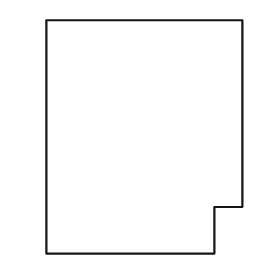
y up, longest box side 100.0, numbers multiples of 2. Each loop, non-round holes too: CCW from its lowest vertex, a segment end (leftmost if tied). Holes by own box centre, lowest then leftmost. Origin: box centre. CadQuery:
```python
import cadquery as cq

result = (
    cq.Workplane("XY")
    .moveTo(-42.0, -50.0)
    .lineTo(30.0, -50.0)
    .lineTo(30.0, -30.0)
    .lineTo(42.0, -30.0)
    .lineTo(42.0, 50.0)
    .lineTo(-42.0, 50.0)
    .close()
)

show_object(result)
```